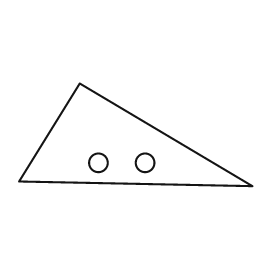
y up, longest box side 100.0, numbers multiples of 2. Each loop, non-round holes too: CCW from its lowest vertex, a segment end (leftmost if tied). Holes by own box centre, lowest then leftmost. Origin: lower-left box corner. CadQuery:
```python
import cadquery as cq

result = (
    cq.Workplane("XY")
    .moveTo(100.0, 0.0)
    .lineTo(26.0, 44.0)
    .lineTo(0.0, 2.0)
    .close()
    .moveTo(34.0, 10.0)
    .circle(4.0)
    .moveTo(54.0, 10.0)
    .circle(4.0)
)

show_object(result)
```